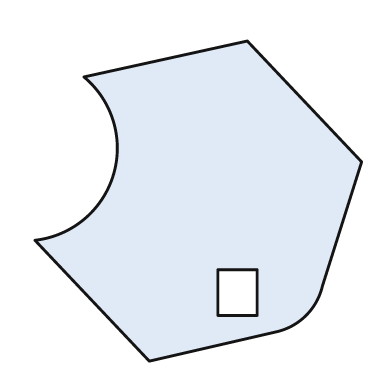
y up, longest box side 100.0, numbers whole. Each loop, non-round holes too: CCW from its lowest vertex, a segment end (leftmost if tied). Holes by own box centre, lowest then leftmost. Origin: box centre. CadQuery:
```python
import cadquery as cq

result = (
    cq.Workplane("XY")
    .moveTo(-15.0, -49.0)
    .lineTo(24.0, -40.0)
    .threePointArc((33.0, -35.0), (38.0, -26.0))
    .lineTo(50.0, 12.0)
    .lineTo(15.0, 49.0)
    .lineTo(-35.0, 38.0)
    .threePointArc((-26.0, 8.0), (-50.0, -12.0))
    .close()
    .moveTo(6.0, -35.0)
    .lineTo(18.0, -35.0)
    .lineTo(18.0, -21.0)
    .lineTo(6.0, -21.0)
    .close()
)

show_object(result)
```